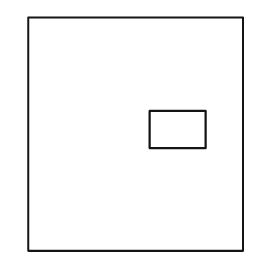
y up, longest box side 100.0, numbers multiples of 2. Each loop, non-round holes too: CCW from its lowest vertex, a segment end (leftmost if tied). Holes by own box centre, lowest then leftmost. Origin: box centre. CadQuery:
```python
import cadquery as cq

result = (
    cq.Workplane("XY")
    .moveTo(-46.0, -50.0)
    .lineTo(46.0, -50.0)
    .lineTo(46.0, 50.0)
    .lineTo(-46.0, 50.0)
    .close()
    .moveTo(6.0, -6.0)
    .lineTo(30.0, -6.0)
    .lineTo(30.0, 10.0)
    .lineTo(6.0, 10.0)
    .close()
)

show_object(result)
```